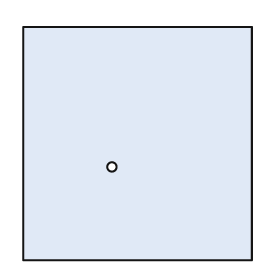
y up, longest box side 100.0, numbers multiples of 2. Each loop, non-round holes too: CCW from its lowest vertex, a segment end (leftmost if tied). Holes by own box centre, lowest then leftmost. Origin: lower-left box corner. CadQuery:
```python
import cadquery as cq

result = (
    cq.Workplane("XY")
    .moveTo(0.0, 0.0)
    .lineTo(98.0, 0.0)
    .lineTo(98.0, 100.0)
    .lineTo(0.0, 100.0)
    .close()
    .moveTo(38.0, 40.0)
    .circle(2.0)
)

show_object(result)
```